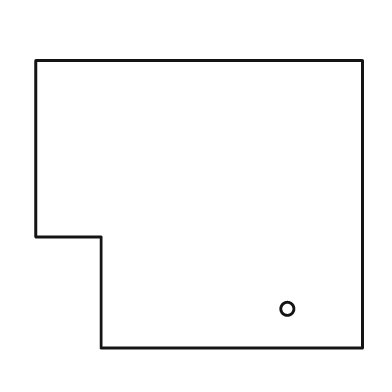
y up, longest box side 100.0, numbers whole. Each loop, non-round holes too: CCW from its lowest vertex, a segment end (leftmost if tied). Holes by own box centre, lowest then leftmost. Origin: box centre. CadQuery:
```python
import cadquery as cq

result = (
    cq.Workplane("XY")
    .moveTo(-30.0, -44.0)
    .lineTo(50.0, -44.0)
    .lineTo(50.0, 44.0)
    .lineTo(-50.0, 44.0)
    .lineTo(-50.0, -10.0)
    .lineTo(-30.0, -10.0)
    .close()
    .moveTo(27.0, -32.0)
    .circle(2.0)
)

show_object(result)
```